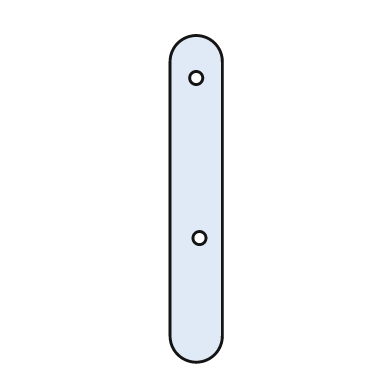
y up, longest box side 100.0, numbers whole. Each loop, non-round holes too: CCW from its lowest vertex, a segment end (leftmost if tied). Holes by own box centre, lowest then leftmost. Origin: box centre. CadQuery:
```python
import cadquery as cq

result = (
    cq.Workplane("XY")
    .moveTo(-8.0, -42.0)
    .threePointArc((0.0, -50.0), (8.0, -42.0))
    .lineTo(8.0, 42.0)
    .threePointArc((0.0, 50.0), (-8.0, 42.0))
    .close()
    .moveTo(1.0, -12.0)
    .circle(2.0)
    .moveTo(0.0, 37.0)
    .circle(2.0)
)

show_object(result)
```